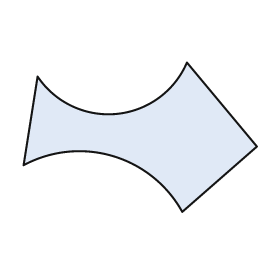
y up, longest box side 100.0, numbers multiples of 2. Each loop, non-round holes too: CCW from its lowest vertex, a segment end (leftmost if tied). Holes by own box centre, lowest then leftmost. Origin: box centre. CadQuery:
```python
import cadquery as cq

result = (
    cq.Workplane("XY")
    .moveTo(18.0, -32.0)
    .lineTo(50.0, -4.0)
    .lineTo(20.0, 32.0)
    .threePointArc((-10.0, 10.0), (-44.0, 26.0))
    .lineTo(-50.0, -12.0)
    .threePointArc((-12.0, -8.0), (18.0, -32.0))
    .close()
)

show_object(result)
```